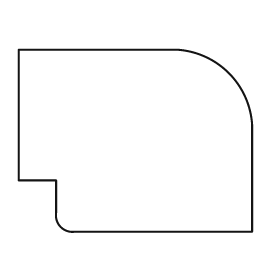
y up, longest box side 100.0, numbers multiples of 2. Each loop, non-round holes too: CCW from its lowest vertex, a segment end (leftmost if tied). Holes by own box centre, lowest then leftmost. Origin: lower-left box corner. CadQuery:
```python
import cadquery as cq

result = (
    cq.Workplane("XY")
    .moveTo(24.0, 0.0)
    .lineTo(100.0, 0.0)
    .lineTo(100.0, 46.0)
    .threePointArc((90.0, 68.0), (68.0, 78.0))
    .lineTo(0.0, 78.0)
    .lineTo(0.0, 22.0)
    .lineTo(16.0, 22.0)
    .lineTo(16.0, 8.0)
    .threePointArc((18.0, 2.0), (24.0, 0.0))
    .close()
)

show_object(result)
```